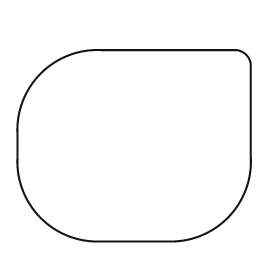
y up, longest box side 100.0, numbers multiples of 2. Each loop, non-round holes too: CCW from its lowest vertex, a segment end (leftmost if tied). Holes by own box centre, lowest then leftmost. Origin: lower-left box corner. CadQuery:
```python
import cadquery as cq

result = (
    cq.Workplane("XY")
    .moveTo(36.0, 0.0)
    .lineTo(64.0, 0.0)
    .threePointArc((90.0, 10.0), (100.0, 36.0))
    .lineTo(100.0, 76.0)
    .threePointArc((98.0, 80.0), (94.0, 82.0))
    .lineTo(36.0, 82.0)
    .threePointArc((10.0, 72.0), (0.0, 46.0))
    .lineTo(0.0, 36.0)
    .threePointArc((10.0, 10.0), (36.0, 0.0))
    .close()
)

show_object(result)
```